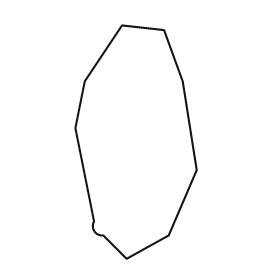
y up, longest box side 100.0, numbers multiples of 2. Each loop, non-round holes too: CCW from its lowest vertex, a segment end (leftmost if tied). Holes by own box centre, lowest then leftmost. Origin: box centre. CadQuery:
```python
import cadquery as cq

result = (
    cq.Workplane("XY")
    .moveTo(-4.0, -50.0)
    .lineTo(14.0, -40.0)
    .lineTo(26.0, -12.0)
    .lineTo(20.0, 26.0)
    .lineTo(12.0, 48.0)
    .lineTo(-6.0, 50.0)
    .lineTo(-22.0, 26.0)
    .lineTo(-26.0, 6.0)
    .lineTo(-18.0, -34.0)
    .threePointArc((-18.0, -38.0), (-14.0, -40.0))
    .close()
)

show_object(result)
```